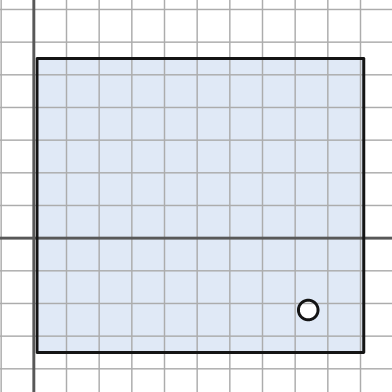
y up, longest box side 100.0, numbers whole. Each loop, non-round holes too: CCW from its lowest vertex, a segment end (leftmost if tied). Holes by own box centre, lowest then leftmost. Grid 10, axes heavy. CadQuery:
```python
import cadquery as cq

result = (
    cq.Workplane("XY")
    .moveTo(1.0, -35.0)
    .lineTo(101.0, -35.0)
    .lineTo(101.0, 55.0)
    .lineTo(1.0, 55.0)
    .close()
    .moveTo(84.0, -22.0)
    .circle(3.0)
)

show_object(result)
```